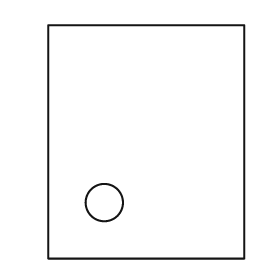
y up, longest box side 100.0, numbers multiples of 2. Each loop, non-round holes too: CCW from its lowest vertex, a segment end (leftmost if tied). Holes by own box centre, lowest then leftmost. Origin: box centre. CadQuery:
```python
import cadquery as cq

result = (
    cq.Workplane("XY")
    .moveTo(-42.0, -50.0)
    .lineTo(42.0, -50.0)
    .lineTo(42.0, 50.0)
    .lineTo(-42.0, 50.0)
    .close()
    .moveTo(-18.0, -26.0)
    .circle(8.0)
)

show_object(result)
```